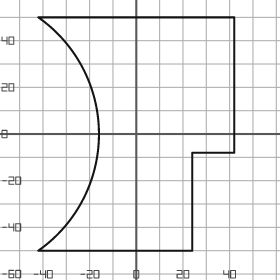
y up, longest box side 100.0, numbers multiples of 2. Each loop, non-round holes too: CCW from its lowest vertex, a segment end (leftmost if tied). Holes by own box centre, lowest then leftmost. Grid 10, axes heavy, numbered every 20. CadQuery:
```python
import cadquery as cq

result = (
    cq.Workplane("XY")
    .moveTo(-42.0, -50.0)
    .lineTo(24.0, -50.0)
    .lineTo(24.0, -8.0)
    .lineTo(42.0, -8.0)
    .lineTo(42.0, 50.0)
    .lineTo(-42.0, 50.0)
    .threePointArc((-16.0, 0.0), (-42.0, -50.0))
    .close()
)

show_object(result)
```